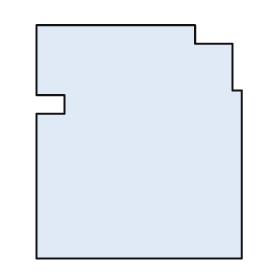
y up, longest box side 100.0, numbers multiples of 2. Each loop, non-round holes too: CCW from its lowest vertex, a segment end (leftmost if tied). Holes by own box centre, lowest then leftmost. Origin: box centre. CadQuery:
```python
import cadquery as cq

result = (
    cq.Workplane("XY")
    .moveTo(-44.0, -50.0)
    .lineTo(44.0, -50.0)
    .lineTo(44.0, 22.0)
    .lineTo(40.0, 22.0)
    .lineTo(40.0, 42.0)
    .lineTo(24.0, 42.0)
    .lineTo(24.0, 50.0)
    .lineTo(-44.0, 50.0)
    .lineTo(-44.0, 20.0)
    .lineTo(-32.0, 20.0)
    .lineTo(-32.0, 12.0)
    .lineTo(-44.0, 12.0)
    .close()
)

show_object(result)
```